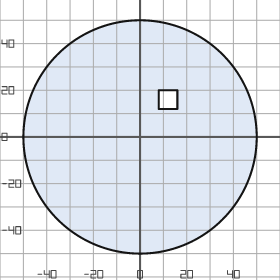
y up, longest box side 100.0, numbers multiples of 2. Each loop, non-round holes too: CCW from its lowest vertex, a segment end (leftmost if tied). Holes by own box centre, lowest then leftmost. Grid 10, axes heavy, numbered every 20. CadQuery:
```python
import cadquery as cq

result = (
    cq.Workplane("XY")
    .moveTo(0.0, 0.0)
    .circle(50.0)
    .moveTo(8.0, 12.0)
    .lineTo(16.0, 12.0)
    .lineTo(16.0, 20.0)
    .lineTo(8.0, 20.0)
    .close()
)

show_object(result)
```